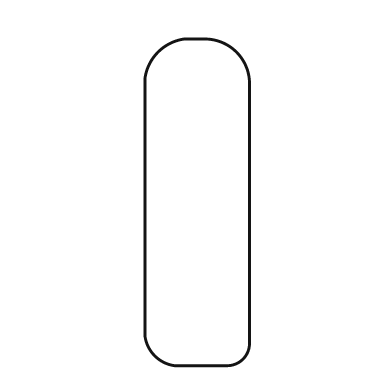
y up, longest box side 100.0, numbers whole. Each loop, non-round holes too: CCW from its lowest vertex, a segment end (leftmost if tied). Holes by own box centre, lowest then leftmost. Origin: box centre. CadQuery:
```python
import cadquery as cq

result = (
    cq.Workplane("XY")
    .moveTo(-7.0, -50.0)
    .lineTo(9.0, -50.0)
    .threePointArc((14.0, -48.0), (16.0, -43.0))
    .lineTo(16.0, 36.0)
    .threePointArc((12.0, 46.0), (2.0, 50.0))
    .lineTo(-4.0, 50.0)
    .threePointArc((-12.0, 46.0), (-16.0, 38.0))
    .lineTo(-16.0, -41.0)
    .threePointArc((-13.0, -47.0), (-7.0, -50.0))
    .close()
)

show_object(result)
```